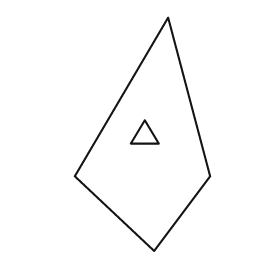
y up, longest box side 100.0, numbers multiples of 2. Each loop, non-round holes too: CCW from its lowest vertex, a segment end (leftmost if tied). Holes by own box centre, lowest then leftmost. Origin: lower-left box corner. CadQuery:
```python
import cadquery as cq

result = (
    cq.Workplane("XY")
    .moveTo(34.0, 0.0)
    .lineTo(58.0, 32.0)
    .lineTo(40.0, 100.0)
    .lineTo(0.0, 32.0)
    .close()
    .moveTo(24.0, 46.0)
    .lineTo(36.0, 46.0)
    .lineTo(30.0, 56.0)
    .close()
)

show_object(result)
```